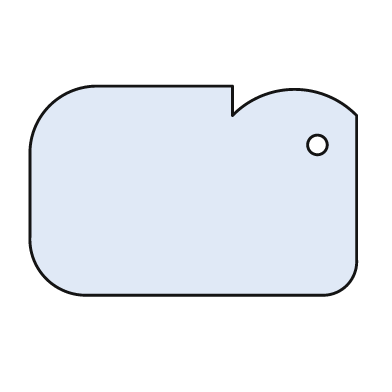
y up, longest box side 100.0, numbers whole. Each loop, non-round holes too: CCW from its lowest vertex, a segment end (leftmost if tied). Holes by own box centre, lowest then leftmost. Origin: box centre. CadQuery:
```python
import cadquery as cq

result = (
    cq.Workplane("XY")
    .moveTo(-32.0, -32.0)
    .lineTo(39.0, -32.0)
    .threePointArc((47.0, -29.0), (50.0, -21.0))
    .lineTo(50.0, 23.0)
    .threePointArc((31.0, 31.0), (12.0, 23.0))
    .lineTo(12.0, 32.0)
    .lineTo(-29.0, 32.0)
    .threePointArc((-44.0, 26.0), (-50.0, 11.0))
    .lineTo(-50.0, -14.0)
    .threePointArc((-45.0, -27.0), (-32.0, -32.0))
    .close()
    .moveTo(38.0, 14.0)
    .circle(3.0)
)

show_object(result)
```